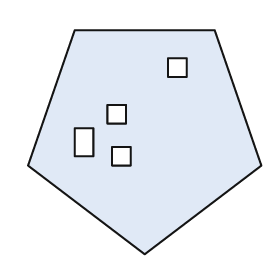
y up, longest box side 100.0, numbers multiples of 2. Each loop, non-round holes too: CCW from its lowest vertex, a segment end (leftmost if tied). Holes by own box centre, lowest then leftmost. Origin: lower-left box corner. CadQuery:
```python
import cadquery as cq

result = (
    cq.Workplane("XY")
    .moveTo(50.0, 0.0)
    .lineTo(100.0, 38.0)
    .lineTo(80.0, 96.0)
    .lineTo(20.0, 96.0)
    .lineTo(0.0, 38.0)
    .close()
    .moveTo(36.0, 38.0)
    .lineTo(44.0, 38.0)
    .lineTo(44.0, 46.0)
    .lineTo(36.0, 46.0)
    .close()
    .moveTo(20.0, 42.0)
    .lineTo(28.0, 42.0)
    .lineTo(28.0, 54.0)
    .lineTo(20.0, 54.0)
    .close()
    .moveTo(34.0, 56.0)
    .lineTo(42.0, 56.0)
    .lineTo(42.0, 64.0)
    .lineTo(34.0, 64.0)
    .close()
    .moveTo(60.0, 76.0)
    .lineTo(68.0, 76.0)
    .lineTo(68.0, 84.0)
    .lineTo(60.0, 84.0)
    .close()
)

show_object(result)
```